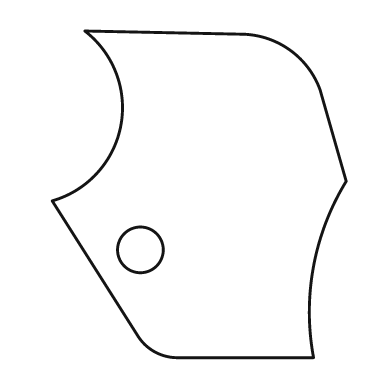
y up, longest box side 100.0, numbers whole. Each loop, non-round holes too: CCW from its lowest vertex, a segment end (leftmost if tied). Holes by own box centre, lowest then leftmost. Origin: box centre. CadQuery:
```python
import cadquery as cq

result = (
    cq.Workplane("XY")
    .moveTo(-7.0, -50.0)
    .lineTo(35.0, -50.0)
    .threePointArc((35.0, -22.0), (45.0, 4.0))
    .lineTo(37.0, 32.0)
    .threePointArc((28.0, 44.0), (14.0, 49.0))
    .lineTo(-35.0, 50.0)
    .threePointArc((-24.0, 21.0), (-45.0, -2.0))
    .lineTo(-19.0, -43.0)
    .threePointArc((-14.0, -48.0), (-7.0, -50.0))
    .close()
    .moveTo(-18.0, -17.0)
    .circle(7.0)
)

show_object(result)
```